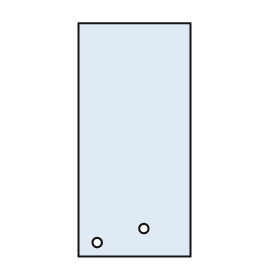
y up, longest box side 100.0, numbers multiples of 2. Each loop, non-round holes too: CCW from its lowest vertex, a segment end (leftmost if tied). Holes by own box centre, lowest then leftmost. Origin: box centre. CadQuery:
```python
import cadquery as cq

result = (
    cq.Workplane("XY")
    .moveTo(-24.0, -50.0)
    .lineTo(24.0, -50.0)
    .lineTo(24.0, 50.0)
    .lineTo(-24.0, 50.0)
    .close()
    .moveTo(-16.0, -44.0)
    .circle(2.0)
    .moveTo(4.0, -38.0)
    .circle(2.0)
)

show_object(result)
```